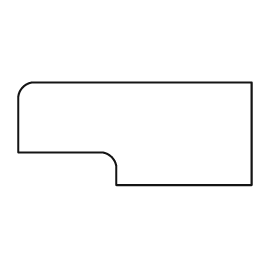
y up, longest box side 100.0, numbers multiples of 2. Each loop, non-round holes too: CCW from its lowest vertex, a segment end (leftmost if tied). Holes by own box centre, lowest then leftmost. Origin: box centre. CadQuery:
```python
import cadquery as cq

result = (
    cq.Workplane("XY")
    .moveTo(-8.0, -22.0)
    .lineTo(50.0, -22.0)
    .lineTo(50.0, 22.0)
    .lineTo(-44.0, 22.0)
    .threePointArc((-48.0, 20.0), (-50.0, 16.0))
    .lineTo(-50.0, -8.0)
    .lineTo(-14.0, -8.0)
    .threePointArc((-10.0, -10.0), (-8.0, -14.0))
    .close()
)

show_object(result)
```